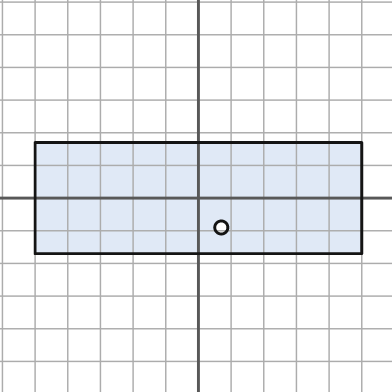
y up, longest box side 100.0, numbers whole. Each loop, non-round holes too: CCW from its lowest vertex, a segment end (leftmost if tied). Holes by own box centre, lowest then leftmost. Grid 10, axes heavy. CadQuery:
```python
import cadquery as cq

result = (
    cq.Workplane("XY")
    .moveTo(-50.0, -17.0)
    .lineTo(50.0, -17.0)
    .lineTo(50.0, 17.0)
    .lineTo(-50.0, 17.0)
    .close()
    .moveTo(7.0, -9.0)
    .circle(2.0)
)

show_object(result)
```